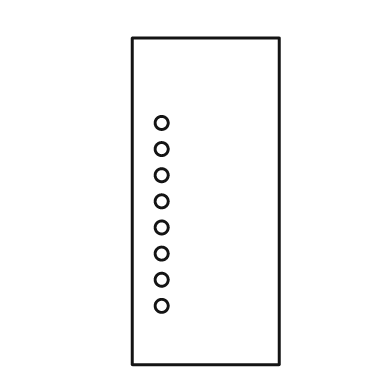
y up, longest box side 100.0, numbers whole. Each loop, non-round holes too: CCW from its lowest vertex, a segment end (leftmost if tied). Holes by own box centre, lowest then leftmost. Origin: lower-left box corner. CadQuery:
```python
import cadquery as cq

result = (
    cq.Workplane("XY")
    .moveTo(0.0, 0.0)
    .lineTo(45.0, 0.0)
    .lineTo(45.0, 100.0)
    .lineTo(0.0, 100.0)
    .close()
    .moveTo(9.0, 18.0)
    .circle(2.0)
    .moveTo(9.0, 26.0)
    .circle(2.0)
    .moveTo(9.0, 34.0)
    .circle(2.0)
    .moveTo(9.0, 42.0)
    .circle(2.0)
    .moveTo(9.0, 50.0)
    .circle(2.0)
    .moveTo(9.0, 58.0)
    .circle(2.0)
    .moveTo(9.0, 66.0)
    .circle(2.0)
    .moveTo(9.0, 74.0)
    .circle(2.0)
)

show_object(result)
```